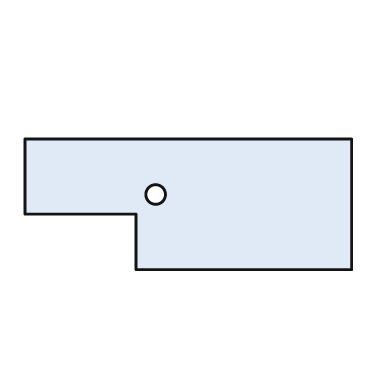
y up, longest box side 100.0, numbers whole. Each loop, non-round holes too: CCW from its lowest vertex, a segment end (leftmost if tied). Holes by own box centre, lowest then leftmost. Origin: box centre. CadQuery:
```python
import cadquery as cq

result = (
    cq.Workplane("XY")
    .moveTo(-16.0, -20.0)
    .lineTo(50.0, -20.0)
    .lineTo(50.0, 20.0)
    .lineTo(-50.0, 20.0)
    .lineTo(-50.0, -3.0)
    .lineTo(-16.0, -3.0)
    .close()
    .moveTo(-10.0, 3.0)
    .circle(3.0)
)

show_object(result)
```